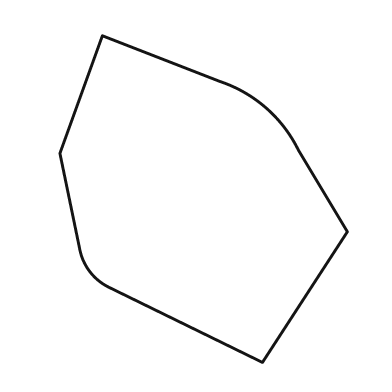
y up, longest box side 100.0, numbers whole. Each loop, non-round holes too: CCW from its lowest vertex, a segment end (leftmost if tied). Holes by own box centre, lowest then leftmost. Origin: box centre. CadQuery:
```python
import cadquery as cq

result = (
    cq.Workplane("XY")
    .moveTo(18.0, -50.0)
    .lineTo(44.0, -10.0)
    .lineTo(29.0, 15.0)
    .threePointArc((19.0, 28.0), (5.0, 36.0))
    .lineTo(-31.0, 50.0)
    .lineTo(-44.0, 14.0)
    .lineTo(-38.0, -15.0)
    .threePointArc((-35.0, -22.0), (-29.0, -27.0))
    .close()
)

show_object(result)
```